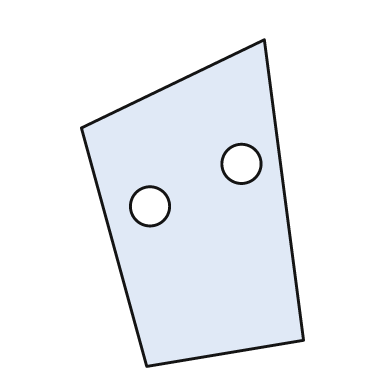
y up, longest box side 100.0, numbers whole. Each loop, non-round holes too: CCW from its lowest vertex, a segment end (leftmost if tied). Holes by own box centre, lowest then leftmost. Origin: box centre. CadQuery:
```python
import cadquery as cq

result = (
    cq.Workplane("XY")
    .moveTo(-14.0, -50.0)
    .lineTo(34.0, -42.0)
    .lineTo(22.0, 50.0)
    .lineTo(-34.0, 23.0)
    .close()
    .moveTo(-13.0, -1.0)
    .circle(6.0)
    .moveTo(15.0, 12.0)
    .circle(6.0)
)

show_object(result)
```